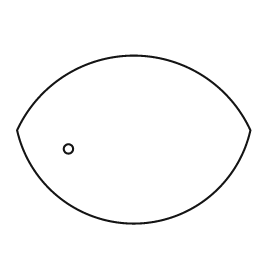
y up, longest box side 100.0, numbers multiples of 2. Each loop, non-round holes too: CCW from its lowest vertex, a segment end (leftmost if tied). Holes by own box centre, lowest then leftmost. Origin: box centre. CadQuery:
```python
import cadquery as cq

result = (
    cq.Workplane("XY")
    .moveTo(-50.0, 4.0)
    .threePointArc((0.0, -36.0), (50.0, 4.0))
    .threePointArc((0.0, 36.0), (-50.0, 4.0))
    .close()
    .moveTo(-28.0, -4.0)
    .circle(2.0)
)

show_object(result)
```